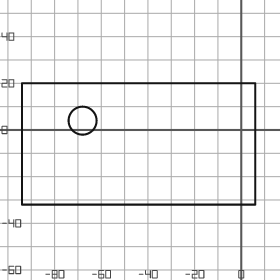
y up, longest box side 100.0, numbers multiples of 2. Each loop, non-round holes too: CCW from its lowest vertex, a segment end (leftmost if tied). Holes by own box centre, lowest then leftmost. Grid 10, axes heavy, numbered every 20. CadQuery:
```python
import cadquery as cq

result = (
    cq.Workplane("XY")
    .moveTo(-94.0, -32.0)
    .lineTo(6.0, -32.0)
    .lineTo(6.0, 20.0)
    .lineTo(-94.0, 20.0)
    .close()
    .moveTo(-68.0, 4.0)
    .circle(6.0)
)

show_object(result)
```